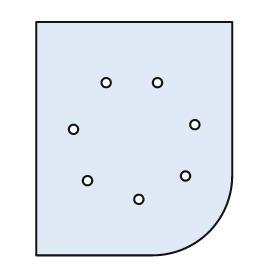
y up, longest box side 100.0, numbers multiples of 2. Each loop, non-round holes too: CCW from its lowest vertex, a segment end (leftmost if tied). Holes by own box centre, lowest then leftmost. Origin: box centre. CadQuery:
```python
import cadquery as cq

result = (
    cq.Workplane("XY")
    .moveTo(-42.0, -50.0)
    .lineTo(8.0, -50.0)
    .threePointArc((32.0, -40.0), (42.0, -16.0))
    .lineTo(42.0, 50.0)
    .lineTo(-42.0, 50.0)
    .close()
    .moveTo(2.0, -26.0)
    .circle(2.0)
    .moveTo(-20.0, -18.0)
    .circle(2.0)
    .moveTo(22.0, -16.0)
    .circle(2.0)
    .moveTo(-26.0, 4.0)
    .circle(2.0)
    .moveTo(26.0, 6.0)
    .circle(2.0)
    .moveTo(-12.0, 24.0)
    .circle(2.0)
    .moveTo(10.0, 24.0)
    .circle(2.0)
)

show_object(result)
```